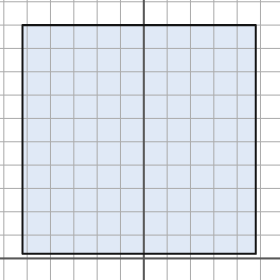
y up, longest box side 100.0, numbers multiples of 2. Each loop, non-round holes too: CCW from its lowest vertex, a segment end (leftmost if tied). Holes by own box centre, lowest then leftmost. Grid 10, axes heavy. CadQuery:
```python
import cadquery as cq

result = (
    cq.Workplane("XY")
    .moveTo(-52.0, 2.0)
    .lineTo(48.0, 2.0)
    .lineTo(48.0, 100.0)
    .lineTo(-52.0, 100.0)
    .close()
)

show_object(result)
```